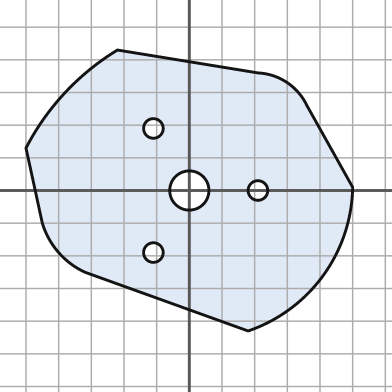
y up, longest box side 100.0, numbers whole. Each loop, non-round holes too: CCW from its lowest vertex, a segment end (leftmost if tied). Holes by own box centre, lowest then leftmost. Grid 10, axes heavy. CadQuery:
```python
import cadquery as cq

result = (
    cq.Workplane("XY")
    .moveTo(18.0, -43.0)
    .threePointArc((41.0, -26.0), (50.0, 1.0))
    .lineTo(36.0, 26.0)
    .threePointArc((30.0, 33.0), (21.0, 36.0))
    .lineTo(-22.0, 43.0)
    .threePointArc((-38.0, 30.0), (-50.0, 13.0))
    .lineTo(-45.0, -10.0)
    .threePointArc((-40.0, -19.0), (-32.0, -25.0))
    .close()
    .moveTo(-11.0, -19.0)
    .circle(3.0)
    .moveTo(0.0, 0.0)
    .circle(6.0)
    .moveTo(21.0, 0.0)
    .circle(3.0)
    .moveTo(-11.0, 19.0)
    .circle(3.0)
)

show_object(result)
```